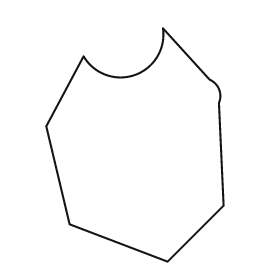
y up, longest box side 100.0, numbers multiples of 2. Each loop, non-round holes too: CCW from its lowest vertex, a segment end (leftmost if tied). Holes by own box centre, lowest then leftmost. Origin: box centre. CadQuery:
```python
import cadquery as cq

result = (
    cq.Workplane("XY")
    .moveTo(14.0, -50.0)
    .lineTo(38.0, -26.0)
    .lineTo(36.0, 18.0)
    .threePointArc((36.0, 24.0), (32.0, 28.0))
    .lineTo(12.0, 50.0)
    .threePointArc((0.0, 30.0), (-22.0, 38.0))
    .lineTo(-38.0, 8.0)
    .lineTo(-28.0, -34.0)
    .close()
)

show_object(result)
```